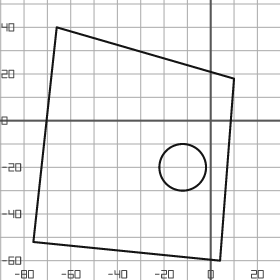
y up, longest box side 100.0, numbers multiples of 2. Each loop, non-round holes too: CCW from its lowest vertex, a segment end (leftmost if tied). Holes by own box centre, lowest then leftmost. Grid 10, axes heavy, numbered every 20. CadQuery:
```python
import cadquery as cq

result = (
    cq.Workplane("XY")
    .moveTo(4.0, -60.0)
    .lineTo(10.0, 18.0)
    .lineTo(-66.0, 40.0)
    .lineTo(-76.0, -52.0)
    .close()
    .moveTo(-12.0, -20.0)
    .circle(10.0)
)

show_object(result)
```